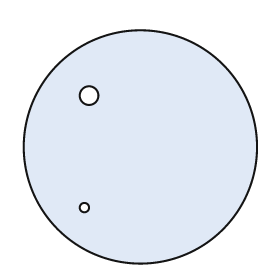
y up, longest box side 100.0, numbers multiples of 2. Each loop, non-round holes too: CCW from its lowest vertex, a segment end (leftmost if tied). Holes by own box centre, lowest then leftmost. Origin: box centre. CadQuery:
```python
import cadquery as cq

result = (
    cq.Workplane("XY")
    .moveTo(0.0, 0.0)
    .circle(50.0)
    .moveTo(-24.0, -26.0)
    .circle(2.0)
    .moveTo(-22.0, 22.0)
    .circle(4.0)
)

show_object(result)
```